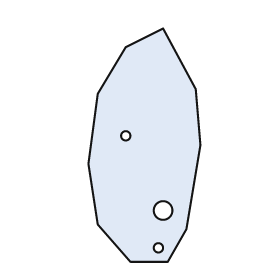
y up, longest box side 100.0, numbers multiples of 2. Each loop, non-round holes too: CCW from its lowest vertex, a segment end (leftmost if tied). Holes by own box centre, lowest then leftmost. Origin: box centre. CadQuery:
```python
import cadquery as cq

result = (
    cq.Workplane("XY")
    .moveTo(-6.0, -50.0)
    .lineTo(10.0, -50.0)
    .lineTo(18.0, -36.0)
    .lineTo(24.0, 0.0)
    .lineTo(22.0, 24.0)
    .lineTo(8.0, 50.0)
    .lineTo(-8.0, 42.0)
    .lineTo(-20.0, 22.0)
    .lineTo(-24.0, -8.0)
    .lineTo(-20.0, -34.0)
    .close()
    .moveTo(6.0, -44.0)
    .circle(2.0)
    .moveTo(8.0, -28.0)
    .circle(4.0)
    .moveTo(-8.0, 4.0)
    .circle(2.0)
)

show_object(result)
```